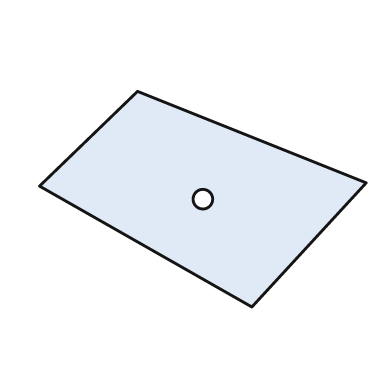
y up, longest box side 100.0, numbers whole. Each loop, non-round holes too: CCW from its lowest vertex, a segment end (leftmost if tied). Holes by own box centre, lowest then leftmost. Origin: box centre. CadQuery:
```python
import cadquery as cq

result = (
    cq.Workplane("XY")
    .moveTo(15.0, -33.0)
    .lineTo(50.0, 5.0)
    .lineTo(-20.0, 33.0)
    .lineTo(-50.0, 4.0)
    .close()
    .moveTo(0.0, 0.0)
    .circle(3.0)
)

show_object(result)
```